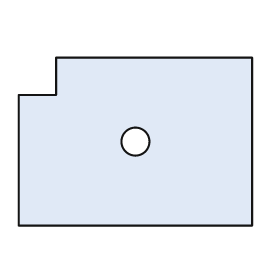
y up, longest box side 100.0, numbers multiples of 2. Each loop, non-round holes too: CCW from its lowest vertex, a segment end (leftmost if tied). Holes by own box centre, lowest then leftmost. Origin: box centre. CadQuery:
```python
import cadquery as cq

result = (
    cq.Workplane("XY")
    .moveTo(-50.0, -36.0)
    .lineTo(50.0, -36.0)
    .lineTo(50.0, 36.0)
    .lineTo(-34.0, 36.0)
    .lineTo(-34.0, 20.0)
    .lineTo(-50.0, 20.0)
    .close()
    .moveTo(0.0, 0.0)
    .circle(6.0)
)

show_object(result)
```